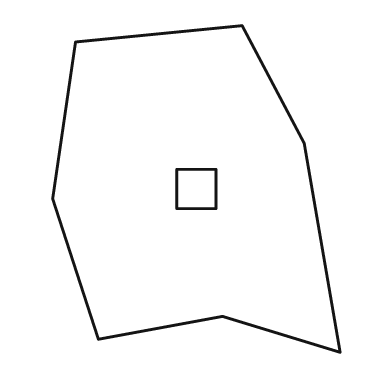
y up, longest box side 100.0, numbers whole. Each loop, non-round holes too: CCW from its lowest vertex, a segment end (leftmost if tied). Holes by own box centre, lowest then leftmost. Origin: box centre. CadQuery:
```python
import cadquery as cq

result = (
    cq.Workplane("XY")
    .moveTo(44.0, -50.0)
    .lineTo(33.0, 14.0)
    .lineTo(14.0, 50.0)
    .lineTo(-37.0, 45.0)
    .lineTo(-44.0, -3.0)
    .lineTo(-30.0, -46.0)
    .lineTo(8.0, -39.0)
    .close()
    .moveTo(-6.0, -6.0)
    .lineTo(6.0, -6.0)
    .lineTo(6.0, 6.0)
    .lineTo(-6.0, 6.0)
    .close()
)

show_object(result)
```